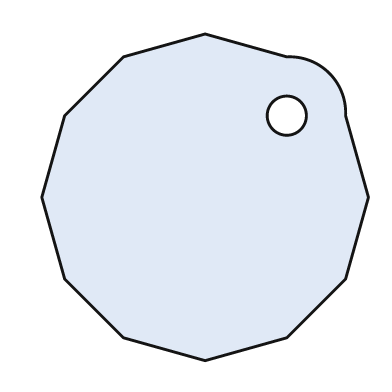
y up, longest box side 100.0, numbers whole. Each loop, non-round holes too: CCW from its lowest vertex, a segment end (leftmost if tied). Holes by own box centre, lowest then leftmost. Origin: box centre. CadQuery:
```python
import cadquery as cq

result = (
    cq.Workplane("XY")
    .moveTo(0.0, -50.0)
    .lineTo(25.0, -43.0)
    .lineTo(43.0, -25.0)
    .lineTo(50.0, 0.0)
    .lineTo(43.0, 25.0)
    .threePointArc((38.0, 38.0), (25.0, 43.0))
    .lineTo(0.0, 50.0)
    .lineTo(-25.0, 43.0)
    .lineTo(-43.0, 25.0)
    .lineTo(-50.0, 0.0)
    .lineTo(-43.0, -25.0)
    .lineTo(-25.0, -43.0)
    .close()
    .moveTo(25.0, 25.0)
    .circle(6.0)
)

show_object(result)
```